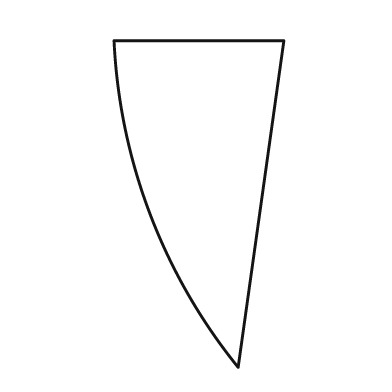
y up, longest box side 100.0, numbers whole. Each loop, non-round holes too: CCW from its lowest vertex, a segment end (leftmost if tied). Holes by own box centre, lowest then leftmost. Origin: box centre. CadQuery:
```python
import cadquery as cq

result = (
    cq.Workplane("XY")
    .moveTo(12.0, -50.0)
    .lineTo(26.0, 50.0)
    .lineTo(-26.0, 50.0)
    .threePointArc((-15.0, -3.0), (12.0, -50.0))
    .close()
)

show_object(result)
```